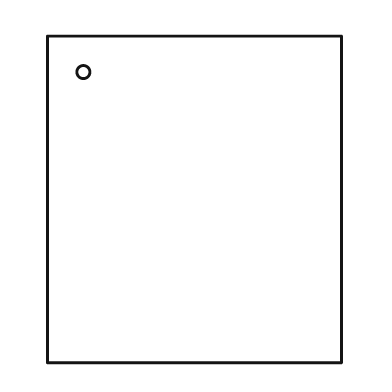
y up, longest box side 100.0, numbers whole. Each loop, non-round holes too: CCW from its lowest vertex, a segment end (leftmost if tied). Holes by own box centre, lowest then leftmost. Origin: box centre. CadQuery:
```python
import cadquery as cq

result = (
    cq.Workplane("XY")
    .moveTo(-45.0, -50.0)
    .lineTo(45.0, -50.0)
    .lineTo(45.0, 50.0)
    .lineTo(-45.0, 50.0)
    .close()
    .moveTo(-34.0, 39.0)
    .circle(2.0)
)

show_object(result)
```